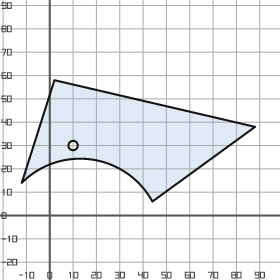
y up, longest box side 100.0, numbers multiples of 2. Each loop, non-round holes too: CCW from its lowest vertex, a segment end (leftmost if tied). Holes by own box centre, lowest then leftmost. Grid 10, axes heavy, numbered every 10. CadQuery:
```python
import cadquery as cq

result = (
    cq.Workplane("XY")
    .moveTo(44.0, 6.0)
    .lineTo(88.0, 38.0)
    .lineTo(2.0, 58.0)
    .lineTo(-12.0, 14.0)
    .threePointArc((18.0, 24.0), (44.0, 6.0))
    .close()
    .moveTo(10.0, 30.0)
    .circle(2.0)
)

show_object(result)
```